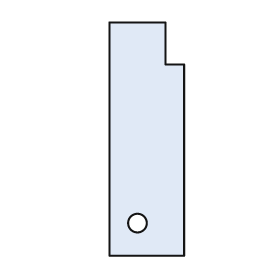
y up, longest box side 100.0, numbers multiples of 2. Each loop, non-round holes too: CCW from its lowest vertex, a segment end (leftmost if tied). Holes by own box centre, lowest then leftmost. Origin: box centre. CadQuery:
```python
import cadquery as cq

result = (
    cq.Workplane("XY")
    .moveTo(-16.0, -50.0)
    .lineTo(16.0, -50.0)
    .lineTo(16.0, 32.0)
    .lineTo(8.0, 32.0)
    .lineTo(8.0, 50.0)
    .lineTo(-16.0, 50.0)
    .close()
    .moveTo(-4.0, -36.0)
    .circle(4.0)
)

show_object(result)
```